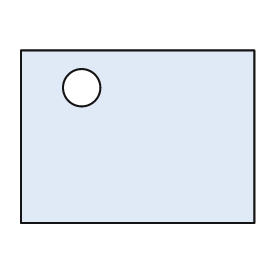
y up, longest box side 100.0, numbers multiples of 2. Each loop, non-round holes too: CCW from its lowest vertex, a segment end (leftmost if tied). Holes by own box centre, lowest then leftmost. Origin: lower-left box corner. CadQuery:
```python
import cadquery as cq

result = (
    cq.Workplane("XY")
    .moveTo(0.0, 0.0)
    .lineTo(100.0, 0.0)
    .lineTo(100.0, 74.0)
    .lineTo(0.0, 74.0)
    .close()
    .moveTo(26.0, 58.0)
    .circle(8.0)
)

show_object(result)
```